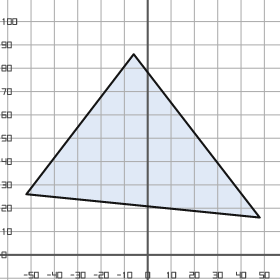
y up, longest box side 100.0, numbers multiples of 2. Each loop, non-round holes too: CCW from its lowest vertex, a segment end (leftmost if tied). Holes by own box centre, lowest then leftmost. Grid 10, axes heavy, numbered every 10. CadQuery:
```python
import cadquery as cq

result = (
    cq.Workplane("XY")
    .moveTo(48.0, 16.0)
    .lineTo(-6.0, 86.0)
    .lineTo(-52.0, 26.0)
    .close()
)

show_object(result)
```